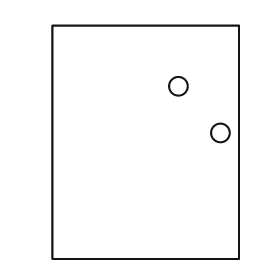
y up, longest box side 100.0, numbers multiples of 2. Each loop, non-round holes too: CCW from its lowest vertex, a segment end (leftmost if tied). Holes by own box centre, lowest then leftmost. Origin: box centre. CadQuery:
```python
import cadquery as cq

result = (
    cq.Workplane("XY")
    .moveTo(-40.0, -50.0)
    .lineTo(40.0, -50.0)
    .lineTo(40.0, 50.0)
    .lineTo(-40.0, 50.0)
    .close()
    .moveTo(32.0, 4.0)
    .circle(4.0)
    .moveTo(14.0, 24.0)
    .circle(4.0)
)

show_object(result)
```